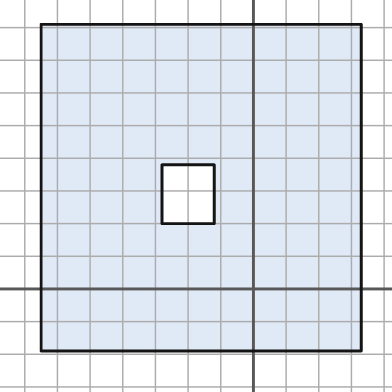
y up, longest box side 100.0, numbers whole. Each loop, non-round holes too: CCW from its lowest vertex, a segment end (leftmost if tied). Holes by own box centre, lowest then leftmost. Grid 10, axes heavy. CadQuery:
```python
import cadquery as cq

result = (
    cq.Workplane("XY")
    .moveTo(-65.0, -19.0)
    .lineTo(33.0, -19.0)
    .lineTo(33.0, 81.0)
    .lineTo(-65.0, 81.0)
    .close()
    .moveTo(-28.0, 20.0)
    .lineTo(-12.0, 20.0)
    .lineTo(-12.0, 38.0)
    .lineTo(-28.0, 38.0)
    .close()
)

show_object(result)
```